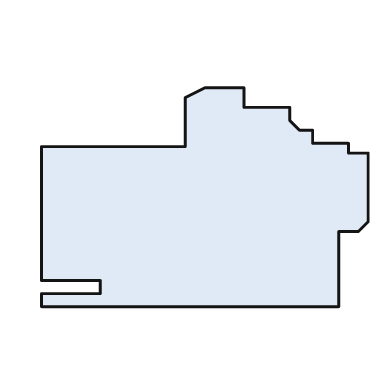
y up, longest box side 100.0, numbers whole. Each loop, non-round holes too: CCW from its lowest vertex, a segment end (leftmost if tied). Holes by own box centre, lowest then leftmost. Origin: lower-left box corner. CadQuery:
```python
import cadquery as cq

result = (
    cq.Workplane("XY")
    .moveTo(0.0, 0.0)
    .lineTo(91.0, 0.0)
    .lineTo(91.0, 23.0)
    .lineTo(97.0, 23.0)
    .lineTo(100.0, 26.0)
    .lineTo(100.0, 47.0)
    .lineTo(94.0, 47.0)
    .lineTo(94.0, 50.0)
    .lineTo(83.0, 50.0)
    .lineTo(83.0, 54.0)
    .lineTo(79.0, 54.0)
    .lineTo(76.0, 57.0)
    .lineTo(76.0, 61.0)
    .lineTo(62.0, 61.0)
    .lineTo(62.0, 67.0)
    .lineTo(50.0, 67.0)
    .lineTo(44.0, 64.0)
    .lineTo(44.0, 49.0)
    .lineTo(0.0, 49.0)
    .lineTo(0.0, 8.0)
    .lineTo(18.0, 8.0)
    .lineTo(18.0, 4.0)
    .lineTo(0.0, 4.0)
    .close()
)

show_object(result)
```